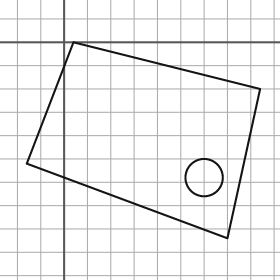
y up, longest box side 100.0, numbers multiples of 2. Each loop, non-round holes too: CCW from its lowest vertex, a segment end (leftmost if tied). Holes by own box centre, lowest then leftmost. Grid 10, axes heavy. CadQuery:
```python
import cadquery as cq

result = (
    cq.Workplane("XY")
    .moveTo(70.0, -84.0)
    .lineTo(84.0, -20.0)
    .lineTo(4.0, 0.0)
    .lineTo(-16.0, -52.0)
    .close()
    .moveTo(60.0, -58.0)
    .circle(8.0)
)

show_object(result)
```